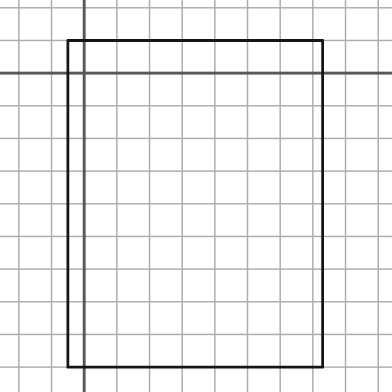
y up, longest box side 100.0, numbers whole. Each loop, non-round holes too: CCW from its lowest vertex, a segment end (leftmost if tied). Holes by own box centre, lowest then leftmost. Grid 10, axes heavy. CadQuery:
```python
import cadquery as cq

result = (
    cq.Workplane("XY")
    .moveTo(-5.0, -90.0)
    .lineTo(73.0, -90.0)
    .lineTo(73.0, 10.0)
    .lineTo(-5.0, 10.0)
    .close()
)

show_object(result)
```